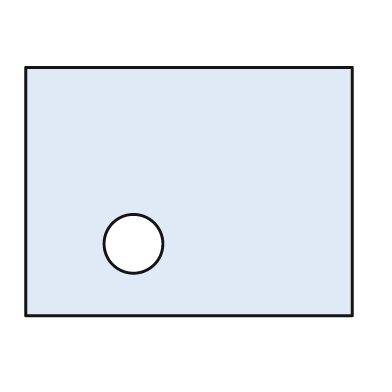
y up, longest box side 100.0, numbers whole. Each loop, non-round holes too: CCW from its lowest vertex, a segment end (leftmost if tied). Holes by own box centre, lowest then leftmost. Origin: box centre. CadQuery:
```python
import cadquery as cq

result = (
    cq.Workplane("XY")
    .moveTo(-50.0, -38.0)
    .lineTo(50.0, -38.0)
    .lineTo(50.0, 38.0)
    .lineTo(-50.0, 38.0)
    .close()
    .moveTo(-17.0, -16.0)
    .circle(9.0)
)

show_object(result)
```